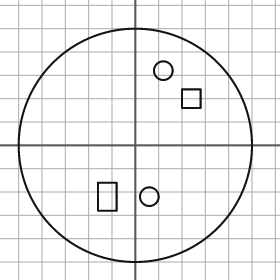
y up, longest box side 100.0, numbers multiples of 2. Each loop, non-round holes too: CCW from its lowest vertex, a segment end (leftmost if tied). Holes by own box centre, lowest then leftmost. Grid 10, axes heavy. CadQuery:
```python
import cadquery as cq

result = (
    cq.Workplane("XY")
    .moveTo(0.0, 0.0)
    .circle(50.0)
    .moveTo(-16.0, -28.0)
    .lineTo(-8.0, -28.0)
    .lineTo(-8.0, -16.0)
    .lineTo(-16.0, -16.0)
    .close()
    .moveTo(6.0, -22.0)
    .circle(4.0)
    .moveTo(20.0, 16.0)
    .lineTo(28.0, 16.0)
    .lineTo(28.0, 24.0)
    .lineTo(20.0, 24.0)
    .close()
    .moveTo(12.0, 32.0)
    .circle(4.0)
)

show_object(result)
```